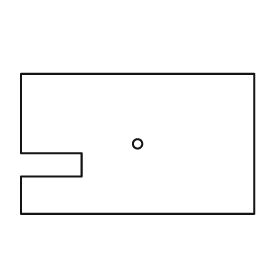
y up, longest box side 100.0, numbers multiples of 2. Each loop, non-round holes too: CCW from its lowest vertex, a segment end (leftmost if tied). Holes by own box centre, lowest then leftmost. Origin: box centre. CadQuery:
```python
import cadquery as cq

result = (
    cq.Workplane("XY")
    .moveTo(-50.0, -30.0)
    .lineTo(50.0, -30.0)
    .lineTo(50.0, 30.0)
    .lineTo(-50.0, 30.0)
    .lineTo(-50.0, -4.0)
    .lineTo(-24.0, -4.0)
    .lineTo(-24.0, -14.0)
    .lineTo(-50.0, -14.0)
    .close()
    .moveTo(0.0, 0.0)
    .circle(2.0)
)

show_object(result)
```